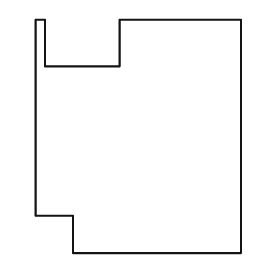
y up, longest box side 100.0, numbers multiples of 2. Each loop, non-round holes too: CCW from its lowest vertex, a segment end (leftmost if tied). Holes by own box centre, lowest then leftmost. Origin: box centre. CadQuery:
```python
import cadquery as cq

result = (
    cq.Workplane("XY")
    .moveTo(-28.0, -50.0)
    .lineTo(44.0, -50.0)
    .lineTo(44.0, 50.0)
    .lineTo(-8.0, 50.0)
    .lineTo(-8.0, 30.0)
    .lineTo(-40.0, 30.0)
    .lineTo(-40.0, 50.0)
    .lineTo(-44.0, 50.0)
    .lineTo(-44.0, -34.0)
    .lineTo(-28.0, -34.0)
    .close()
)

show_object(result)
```